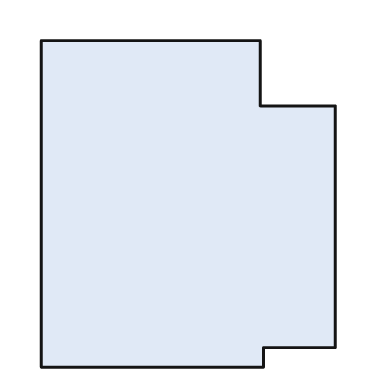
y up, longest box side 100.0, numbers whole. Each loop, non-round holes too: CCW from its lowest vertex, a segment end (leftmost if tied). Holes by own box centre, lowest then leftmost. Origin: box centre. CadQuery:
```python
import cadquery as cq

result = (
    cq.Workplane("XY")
    .moveTo(-45.0, -50.0)
    .lineTo(23.0, -50.0)
    .lineTo(23.0, -44.0)
    .lineTo(45.0, -44.0)
    .lineTo(45.0, 30.0)
    .lineTo(22.0, 30.0)
    .lineTo(22.0, 50.0)
    .lineTo(-45.0, 50.0)
    .close()
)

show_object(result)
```